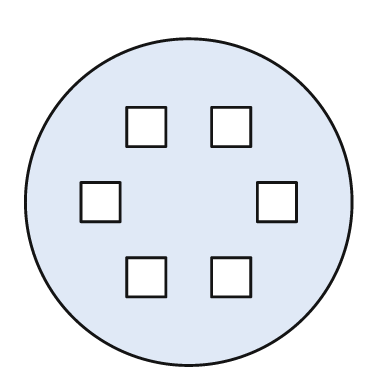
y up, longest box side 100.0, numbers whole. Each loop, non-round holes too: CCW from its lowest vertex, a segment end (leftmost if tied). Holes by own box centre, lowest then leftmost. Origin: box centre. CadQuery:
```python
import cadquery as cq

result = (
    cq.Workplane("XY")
    .moveTo(0.0, 0.0)
    .circle(50.0)
    .moveTo(-19.0, -29.0)
    .lineTo(-7.0, -29.0)
    .lineTo(-7.0, -17.0)
    .lineTo(-19.0, -17.0)
    .close()
    .moveTo(7.0, -29.0)
    .lineTo(19.0, -29.0)
    .lineTo(19.0, -17.0)
    .lineTo(7.0, -17.0)
    .close()
    .moveTo(-33.0, -6.0)
    .lineTo(-21.0, -6.0)
    .lineTo(-21.0, 6.0)
    .lineTo(-33.0, 6.0)
    .close()
    .moveTo(21.0, -6.0)
    .lineTo(33.0, -6.0)
    .lineTo(33.0, 6.0)
    .lineTo(21.0, 6.0)
    .close()
    .moveTo(-19.0, 17.0)
    .lineTo(-7.0, 17.0)
    .lineTo(-7.0, 29.0)
    .lineTo(-19.0, 29.0)
    .close()
    .moveTo(7.0, 17.0)
    .lineTo(19.0, 17.0)
    .lineTo(19.0, 29.0)
    .lineTo(7.0, 29.0)
    .close()
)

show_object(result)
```